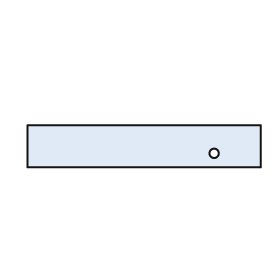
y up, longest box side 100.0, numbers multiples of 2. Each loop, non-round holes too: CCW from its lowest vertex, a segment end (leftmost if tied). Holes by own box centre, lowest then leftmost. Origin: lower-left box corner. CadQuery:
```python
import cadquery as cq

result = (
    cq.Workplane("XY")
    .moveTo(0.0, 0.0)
    .lineTo(100.0, 0.0)
    .lineTo(100.0, 18.0)
    .lineTo(0.0, 18.0)
    .close()
    .moveTo(80.0, 6.0)
    .circle(2.0)
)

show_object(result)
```